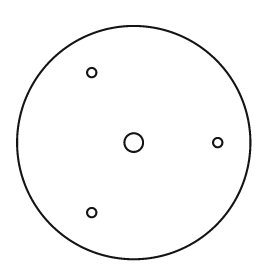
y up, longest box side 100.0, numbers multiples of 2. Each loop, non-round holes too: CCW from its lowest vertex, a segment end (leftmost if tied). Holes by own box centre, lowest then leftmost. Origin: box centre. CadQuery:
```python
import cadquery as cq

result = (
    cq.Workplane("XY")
    .moveTo(0.0, 0.0)
    .circle(50.0)
    .moveTo(-18.0, -30.0)
    .circle(2.0)
    .moveTo(0.0, 0.0)
    .circle(4.0)
    .moveTo(36.0, 0.0)
    .circle(2.0)
    .moveTo(-18.0, 30.0)
    .circle(2.0)
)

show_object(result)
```